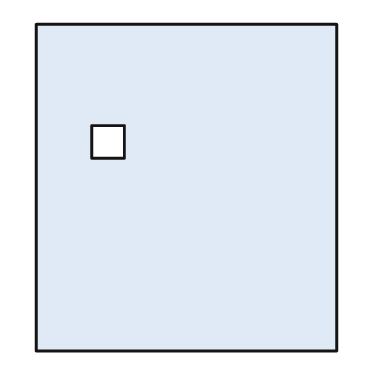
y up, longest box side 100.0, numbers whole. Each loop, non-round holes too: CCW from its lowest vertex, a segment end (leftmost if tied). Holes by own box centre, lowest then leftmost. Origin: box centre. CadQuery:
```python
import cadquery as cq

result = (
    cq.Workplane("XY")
    .moveTo(-46.0, -50.0)
    .lineTo(46.0, -50.0)
    .lineTo(46.0, 50.0)
    .lineTo(-46.0, 50.0)
    .close()
    .moveTo(-29.0, 9.0)
    .lineTo(-19.0, 9.0)
    .lineTo(-19.0, 19.0)
    .lineTo(-29.0, 19.0)
    .close()
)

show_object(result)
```